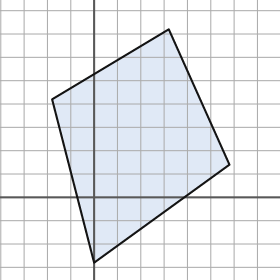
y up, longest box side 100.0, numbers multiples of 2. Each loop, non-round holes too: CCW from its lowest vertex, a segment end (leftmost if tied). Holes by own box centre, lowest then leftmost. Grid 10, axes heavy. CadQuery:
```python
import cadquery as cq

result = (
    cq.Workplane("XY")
    .moveTo(0.0, -28.0)
    .lineTo(58.0, 14.0)
    .lineTo(32.0, 72.0)
    .lineTo(-18.0, 42.0)
    .close()
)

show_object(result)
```